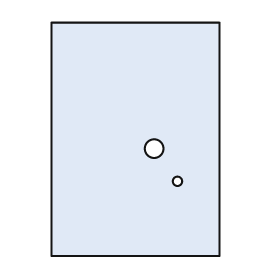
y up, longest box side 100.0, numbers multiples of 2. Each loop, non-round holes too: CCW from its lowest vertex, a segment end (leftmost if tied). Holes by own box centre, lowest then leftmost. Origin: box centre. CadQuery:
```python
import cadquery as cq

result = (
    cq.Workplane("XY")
    .moveTo(-36.0, -50.0)
    .lineTo(36.0, -50.0)
    .lineTo(36.0, 50.0)
    .lineTo(-36.0, 50.0)
    .close()
    .moveTo(18.0, -18.0)
    .circle(2.0)
    .moveTo(8.0, -4.0)
    .circle(4.0)
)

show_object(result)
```